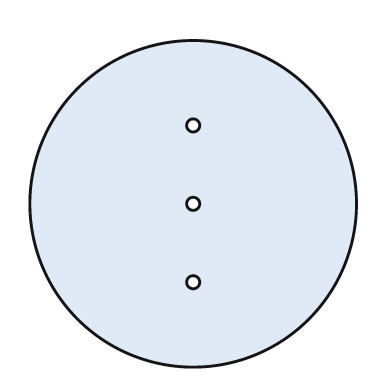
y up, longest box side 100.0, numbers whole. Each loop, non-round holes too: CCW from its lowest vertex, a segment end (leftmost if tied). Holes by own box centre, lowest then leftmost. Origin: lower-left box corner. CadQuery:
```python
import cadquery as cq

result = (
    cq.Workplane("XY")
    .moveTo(50.0, 50.0)
    .circle(50.0)
    .moveTo(50.0, 26.0)
    .circle(2.0)
    .moveTo(50.0, 50.0)
    .circle(2.0)
    .moveTo(50.0, 74.0)
    .circle(2.0)
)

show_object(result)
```